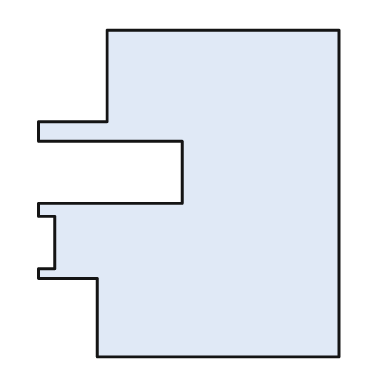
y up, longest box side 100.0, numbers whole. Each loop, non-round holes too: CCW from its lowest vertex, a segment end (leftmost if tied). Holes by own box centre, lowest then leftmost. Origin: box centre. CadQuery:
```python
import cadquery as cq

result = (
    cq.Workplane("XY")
    .moveTo(-28.0, -50.0)
    .lineTo(46.0, -50.0)
    .lineTo(46.0, 50.0)
    .lineTo(-25.0, 50.0)
    .lineTo(-25.0, 22.0)
    .lineTo(-46.0, 22.0)
    .lineTo(-46.0, 16.0)
    .lineTo(-2.0, 16.0)
    .lineTo(-2.0, -3.0)
    .lineTo(-46.0, -3.0)
    .lineTo(-46.0, -7.0)
    .lineTo(-41.0, -7.0)
    .lineTo(-41.0, -23.0)
    .lineTo(-46.0, -23.0)
    .lineTo(-46.0, -26.0)
    .lineTo(-28.0, -26.0)
    .close()
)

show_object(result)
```